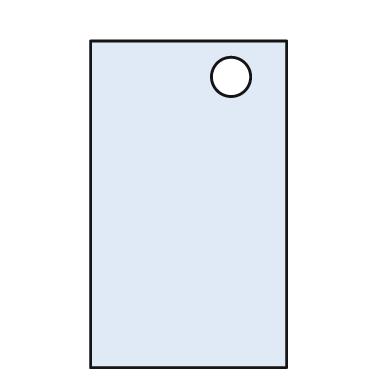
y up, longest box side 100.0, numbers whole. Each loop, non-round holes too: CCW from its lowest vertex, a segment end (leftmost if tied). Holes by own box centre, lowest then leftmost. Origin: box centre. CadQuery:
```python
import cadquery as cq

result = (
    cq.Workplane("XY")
    .moveTo(-30.0, -50.0)
    .lineTo(30.0, -50.0)
    .lineTo(30.0, 50.0)
    .lineTo(-30.0, 50.0)
    .close()
    .moveTo(13.0, 39.0)
    .circle(6.0)
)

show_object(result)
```